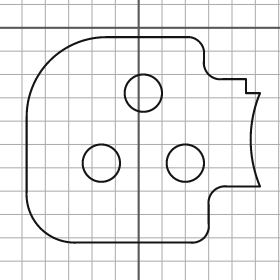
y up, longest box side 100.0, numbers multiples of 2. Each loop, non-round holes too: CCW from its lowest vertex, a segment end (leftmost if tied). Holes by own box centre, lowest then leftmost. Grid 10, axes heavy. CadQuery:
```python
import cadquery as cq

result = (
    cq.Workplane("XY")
    .moveTo(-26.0, -92.0)
    .lineTo(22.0, -92.0)
    .threePointArc((28.0, -90.0), (30.0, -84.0))
    .lineTo(30.0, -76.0)
    .threePointArc((32.0, -70.0), (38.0, -68.0))
    .lineTo(52.0, -68.0)
    .threePointArc((48.0, -48.0), (52.0, -28.0))
    .lineTo(46.0, -28.0)
    .lineTo(46.0, -22.0)
    .lineTo(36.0, -22.0)
    .threePointArc((30.0, -20.0), (28.0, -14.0))
    .lineTo(28.0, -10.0)
    .threePointArc((26.0, -6.0), (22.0, -4.0))
    .lineTo(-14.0, -4.0)
    .threePointArc((-38.0, -14.0), (-48.0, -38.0))
    .lineTo(-48.0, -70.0)
    .threePointArc((-42.0, -86.0), (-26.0, -92.0))
    .close()
    .moveTo(-16.0, -58.0)
    .circle(8.0)
    .moveTo(20.0, -58.0)
    .circle(8.0)
    .moveTo(2.0, -28.0)
    .circle(8.0)
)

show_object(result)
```